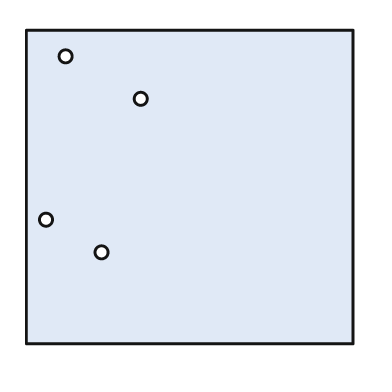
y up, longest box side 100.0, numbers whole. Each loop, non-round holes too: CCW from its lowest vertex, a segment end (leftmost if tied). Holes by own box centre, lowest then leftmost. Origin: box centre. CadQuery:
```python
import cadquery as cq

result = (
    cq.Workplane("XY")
    .moveTo(-50.0, -48.0)
    .lineTo(50.0, -48.0)
    .lineTo(50.0, 48.0)
    .lineTo(-50.0, 48.0)
    .close()
    .moveTo(-27.0, -20.0)
    .circle(2.0)
    .moveTo(-44.0, -10.0)
    .circle(2.0)
    .moveTo(-15.0, 27.0)
    .circle(2.0)
    .moveTo(-38.0, 40.0)
    .circle(2.0)
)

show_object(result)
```